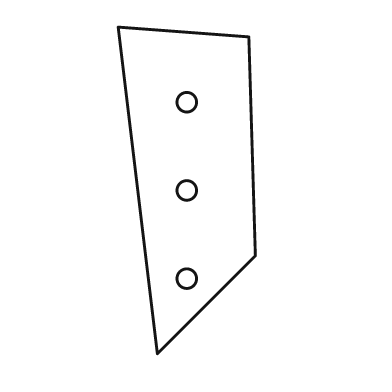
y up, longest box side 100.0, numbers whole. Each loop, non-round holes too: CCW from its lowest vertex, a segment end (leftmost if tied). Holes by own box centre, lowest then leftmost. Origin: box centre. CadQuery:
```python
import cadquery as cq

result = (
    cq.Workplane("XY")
    .moveTo(-9.0, -50.0)
    .lineTo(21.0, -20.0)
    .lineTo(19.0, 47.0)
    .lineTo(-21.0, 50.0)
    .close()
    .moveTo(0.0, -27.0)
    .circle(3.0)
    .moveTo(0.0, 0.0)
    .circle(3.0)
    .moveTo(0.0, 27.0)
    .circle(3.0)
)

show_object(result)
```